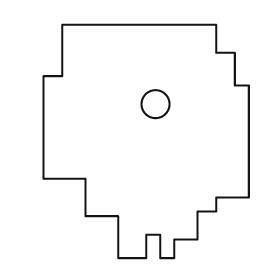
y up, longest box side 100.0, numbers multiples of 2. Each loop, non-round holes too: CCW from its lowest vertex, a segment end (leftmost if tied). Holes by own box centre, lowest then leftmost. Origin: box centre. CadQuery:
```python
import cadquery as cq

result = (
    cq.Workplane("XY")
    .moveTo(-12.0, -50.0)
    .lineTo(0.0, -50.0)
    .lineTo(0.0, -40.0)
    .lineTo(6.0, -40.0)
    .lineTo(6.0, -50.0)
    .lineTo(12.0, -50.0)
    .lineTo(12.0, -42.0)
    .lineTo(22.0, -42.0)
    .lineTo(22.0, -30.0)
    .lineTo(30.0, -30.0)
    .lineTo(30.0, -24.0)
    .lineTo(44.0, -24.0)
    .lineTo(44.0, 24.0)
    .lineTo(38.0, 24.0)
    .lineTo(38.0, 38.0)
    .lineTo(30.0, 38.0)
    .lineTo(30.0, 50.0)
    .lineTo(-36.0, 50.0)
    .lineTo(-36.0, 28.0)
    .lineTo(-44.0, 28.0)
    .lineTo(-44.0, -16.0)
    .lineTo(-26.0, -16.0)
    .lineTo(-26.0, -32.0)
    .lineTo(-12.0, -32.0)
    .close()
    .moveTo(4.0, 16.0)
    .circle(6.0)
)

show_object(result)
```